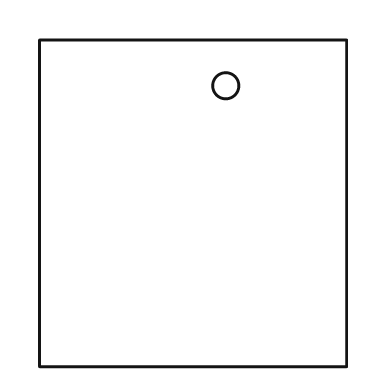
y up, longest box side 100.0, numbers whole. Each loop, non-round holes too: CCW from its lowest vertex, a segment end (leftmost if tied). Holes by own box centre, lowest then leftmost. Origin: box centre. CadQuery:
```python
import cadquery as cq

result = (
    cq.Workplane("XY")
    .moveTo(-47.0, -50.0)
    .lineTo(47.0, -50.0)
    .lineTo(47.0, 50.0)
    .lineTo(-47.0, 50.0)
    .close()
    .moveTo(10.0, 36.0)
    .circle(4.0)
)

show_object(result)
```